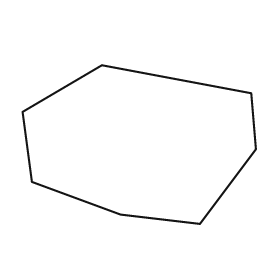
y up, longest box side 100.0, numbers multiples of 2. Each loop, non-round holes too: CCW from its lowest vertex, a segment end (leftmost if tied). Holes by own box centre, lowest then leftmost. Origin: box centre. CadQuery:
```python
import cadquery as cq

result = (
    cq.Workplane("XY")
    .moveTo(26.0, -34.0)
    .lineTo(50.0, -2.0)
    .lineTo(48.0, 22.0)
    .lineTo(-16.0, 34.0)
    .lineTo(-50.0, 14.0)
    .lineTo(-46.0, -16.0)
    .lineTo(-8.0, -30.0)
    .close()
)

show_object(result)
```